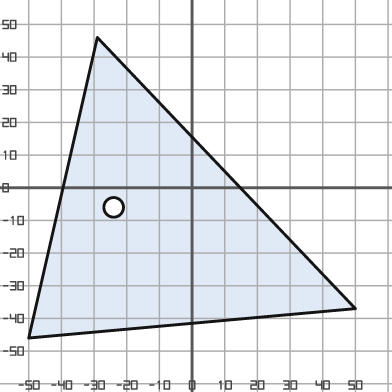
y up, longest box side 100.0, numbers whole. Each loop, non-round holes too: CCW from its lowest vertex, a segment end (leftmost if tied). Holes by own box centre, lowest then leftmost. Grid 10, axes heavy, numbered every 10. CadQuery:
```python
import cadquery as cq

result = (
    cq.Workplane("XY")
    .moveTo(-50.0, -46.0)
    .lineTo(50.0, -37.0)
    .lineTo(-29.0, 46.0)
    .close()
    .moveTo(-24.0, -6.0)
    .circle(3.0)
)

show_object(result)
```